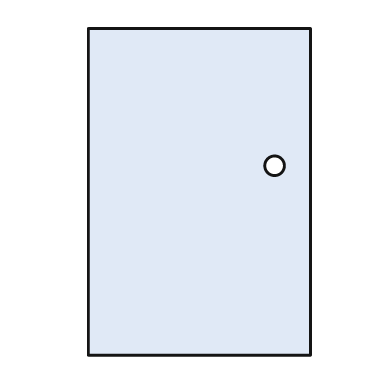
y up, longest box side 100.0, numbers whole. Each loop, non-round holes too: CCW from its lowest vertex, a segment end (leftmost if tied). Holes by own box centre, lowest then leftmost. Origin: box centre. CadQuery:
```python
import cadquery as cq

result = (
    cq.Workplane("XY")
    .moveTo(-34.0, -50.0)
    .lineTo(34.0, -50.0)
    .lineTo(34.0, 50.0)
    .lineTo(-34.0, 50.0)
    .close()
    .moveTo(23.0, 8.0)
    .circle(3.0)
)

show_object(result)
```